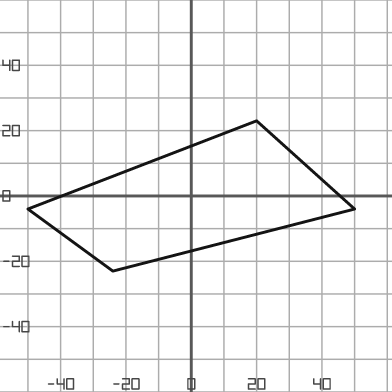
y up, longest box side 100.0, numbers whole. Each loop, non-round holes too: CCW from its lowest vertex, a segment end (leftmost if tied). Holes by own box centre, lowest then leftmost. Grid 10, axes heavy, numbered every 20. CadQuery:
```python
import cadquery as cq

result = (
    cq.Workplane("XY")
    .moveTo(-24.0, -23.0)
    .lineTo(50.0, -4.0)
    .lineTo(20.0, 23.0)
    .lineTo(-50.0, -4.0)
    .close()
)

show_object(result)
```